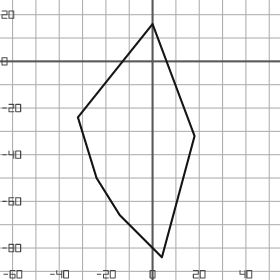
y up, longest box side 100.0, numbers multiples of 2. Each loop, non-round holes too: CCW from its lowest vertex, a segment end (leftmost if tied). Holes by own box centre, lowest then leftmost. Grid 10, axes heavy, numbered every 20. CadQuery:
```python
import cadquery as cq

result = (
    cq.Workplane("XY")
    .moveTo(4.0, -84.0)
    .lineTo(18.0, -32.0)
    .lineTo(0.0, 16.0)
    .lineTo(-32.0, -24.0)
    .lineTo(-24.0, -50.0)
    .lineTo(-14.0, -66.0)
    .close()
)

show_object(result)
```